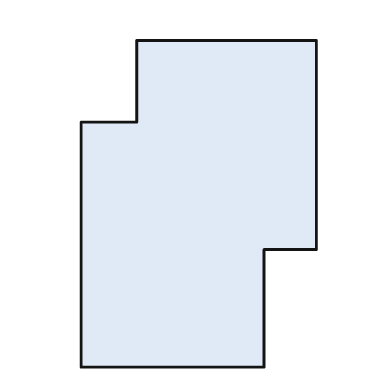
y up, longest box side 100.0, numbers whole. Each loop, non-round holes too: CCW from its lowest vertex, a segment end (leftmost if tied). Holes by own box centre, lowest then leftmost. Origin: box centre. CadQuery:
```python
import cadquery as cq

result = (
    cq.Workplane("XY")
    .moveTo(-36.0, -50.0)
    .lineTo(20.0, -50.0)
    .lineTo(20.0, -14.0)
    .lineTo(36.0, -14.0)
    .lineTo(36.0, 50.0)
    .lineTo(-19.0, 50.0)
    .lineTo(-19.0, 25.0)
    .lineTo(-36.0, 25.0)
    .close()
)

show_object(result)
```